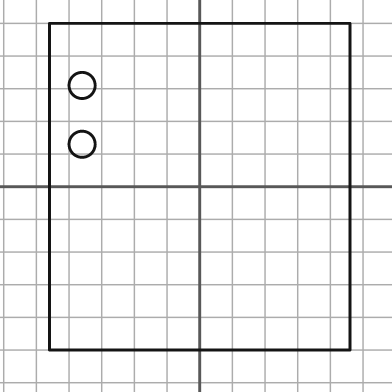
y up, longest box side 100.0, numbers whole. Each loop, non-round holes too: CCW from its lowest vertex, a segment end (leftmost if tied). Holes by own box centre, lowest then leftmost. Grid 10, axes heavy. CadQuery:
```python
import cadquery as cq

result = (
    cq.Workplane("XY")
    .moveTo(-46.0, -50.0)
    .lineTo(46.0, -50.0)
    .lineTo(46.0, 50.0)
    .lineTo(-46.0, 50.0)
    .close()
    .moveTo(-36.0, 13.0)
    .circle(4.0)
    .moveTo(-36.0, 31.0)
    .circle(4.0)
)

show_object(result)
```